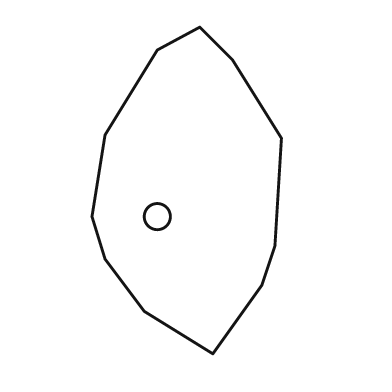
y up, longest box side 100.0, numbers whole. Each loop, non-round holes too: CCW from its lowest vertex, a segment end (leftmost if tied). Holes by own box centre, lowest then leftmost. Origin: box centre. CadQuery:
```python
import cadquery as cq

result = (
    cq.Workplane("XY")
    .moveTo(8.0, -50.0)
    .lineTo(23.0, -29.0)
    .lineTo(27.0, -17.0)
    .lineTo(29.0, 16.0)
    .lineTo(14.0, 40.0)
    .lineTo(4.0, 50.0)
    .lineTo(-9.0, 43.0)
    .lineTo(-25.0, 17.0)
    .lineTo(-29.0, -8.0)
    .lineTo(-25.0, -21.0)
    .lineTo(-13.0, -37.0)
    .close()
    .moveTo(-9.0, -8.0)
    .circle(4.0)
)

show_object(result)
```